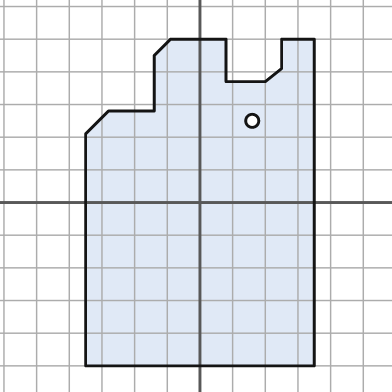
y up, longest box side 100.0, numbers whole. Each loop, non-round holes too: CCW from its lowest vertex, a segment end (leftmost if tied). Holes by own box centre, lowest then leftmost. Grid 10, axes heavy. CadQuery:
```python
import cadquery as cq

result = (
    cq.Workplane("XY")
    .moveTo(-35.0, -50.0)
    .lineTo(35.0, -50.0)
    .lineTo(35.0, 50.0)
    .lineTo(25.0, 50.0)
    .lineTo(25.0, 41.0)
    .lineTo(20.0, 37.0)
    .lineTo(8.0, 37.0)
    .lineTo(8.0, 50.0)
    .lineTo(-9.0, 50.0)
    .lineTo(-14.0, 45.0)
    .lineTo(-14.0, 28.0)
    .lineTo(-28.0, 28.0)
    .lineTo(-35.0, 21.0)
    .close()
    .moveTo(16.0, 25.0)
    .circle(2.0)
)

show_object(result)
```